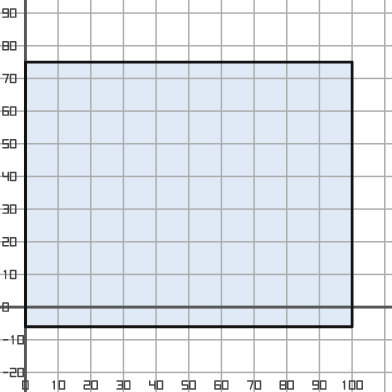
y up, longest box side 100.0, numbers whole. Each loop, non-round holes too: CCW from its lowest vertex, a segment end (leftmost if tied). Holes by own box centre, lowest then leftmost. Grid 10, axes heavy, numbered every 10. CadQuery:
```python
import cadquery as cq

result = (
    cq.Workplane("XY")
    .moveTo(0.0, -6.0)
    .lineTo(100.0, -6.0)
    .lineTo(100.0, 75.0)
    .lineTo(0.0, 75.0)
    .close()
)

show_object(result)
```